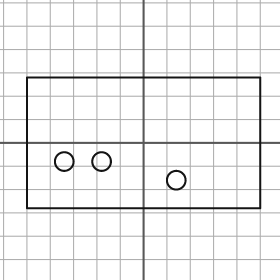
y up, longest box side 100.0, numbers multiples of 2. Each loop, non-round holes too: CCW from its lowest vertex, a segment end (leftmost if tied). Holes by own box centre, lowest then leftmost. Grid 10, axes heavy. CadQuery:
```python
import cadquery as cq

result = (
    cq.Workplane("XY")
    .moveTo(-50.0, -28.0)
    .lineTo(50.0, -28.0)
    .lineTo(50.0, 28.0)
    .lineTo(-50.0, 28.0)
    .close()
    .moveTo(14.0, -16.0)
    .circle(4.0)
    .moveTo(-34.0, -8.0)
    .circle(4.0)
    .moveTo(-18.0, -8.0)
    .circle(4.0)
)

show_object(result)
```